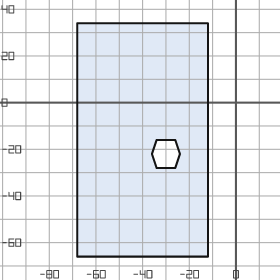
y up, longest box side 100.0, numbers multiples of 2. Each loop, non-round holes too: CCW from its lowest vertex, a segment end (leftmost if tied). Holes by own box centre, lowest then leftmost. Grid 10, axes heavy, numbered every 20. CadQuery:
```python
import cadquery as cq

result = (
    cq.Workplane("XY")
    .moveTo(-68.0, -66.0)
    .lineTo(-12.0, -66.0)
    .lineTo(-12.0, 34.0)
    .lineTo(-68.0, 34.0)
    .close()
    .moveTo(-34.0, -28.0)
    .lineTo(-26.0, -28.0)
    .lineTo(-24.0, -22.0)
    .lineTo(-26.0, -16.0)
    .lineTo(-34.0, -16.0)
    .lineTo(-36.0, -22.0)
    .close()
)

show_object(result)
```